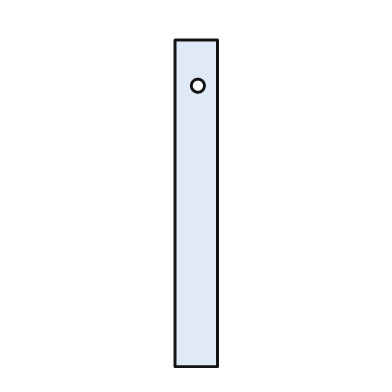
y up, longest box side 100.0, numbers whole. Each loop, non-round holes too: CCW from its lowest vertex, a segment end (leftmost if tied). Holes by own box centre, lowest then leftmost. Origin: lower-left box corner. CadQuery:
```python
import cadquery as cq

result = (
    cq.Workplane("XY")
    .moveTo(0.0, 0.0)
    .lineTo(13.0, 0.0)
    .lineTo(13.0, 100.0)
    .lineTo(0.0, 100.0)
    .close()
    .moveTo(7.0, 86.0)
    .circle(2.0)
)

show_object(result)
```